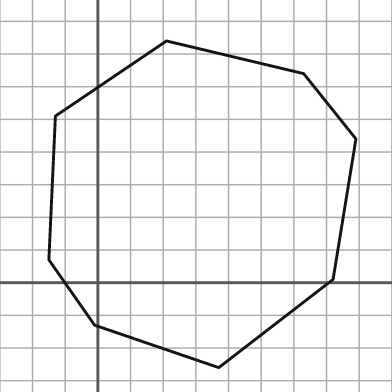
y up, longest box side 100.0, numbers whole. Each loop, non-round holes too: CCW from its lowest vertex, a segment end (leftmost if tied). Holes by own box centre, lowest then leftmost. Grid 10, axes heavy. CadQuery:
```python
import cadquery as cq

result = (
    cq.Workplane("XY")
    .moveTo(37.0, -26.0)
    .lineTo(72.0, 1.0)
    .lineTo(79.0, 44.0)
    .lineTo(63.0, 64.0)
    .lineTo(21.0, 74.0)
    .lineTo(-13.0, 51.0)
    .lineTo(-15.0, 7.0)
    .lineTo(-1.0, -13.0)
    .close()
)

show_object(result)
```